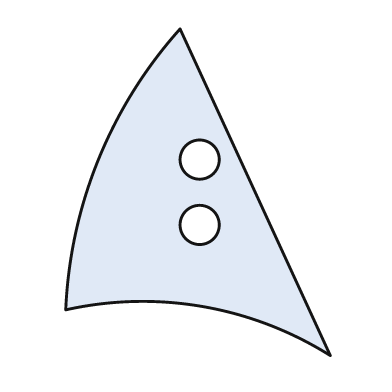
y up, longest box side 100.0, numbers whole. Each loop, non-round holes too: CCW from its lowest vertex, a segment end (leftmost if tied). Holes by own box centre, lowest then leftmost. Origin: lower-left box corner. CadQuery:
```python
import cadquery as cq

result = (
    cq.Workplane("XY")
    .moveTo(81.0, 0.0)
    .lineTo(35.0, 100.0)
    .threePointArc((10.0, 60.0), (0.0, 14.0))
    .threePointArc((42.0, 15.0), (81.0, 0.0))
    .close()
    .moveTo(41.0, 40.0)
    .circle(6.0)
    .moveTo(41.0, 60.0)
    .circle(6.0)
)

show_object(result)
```